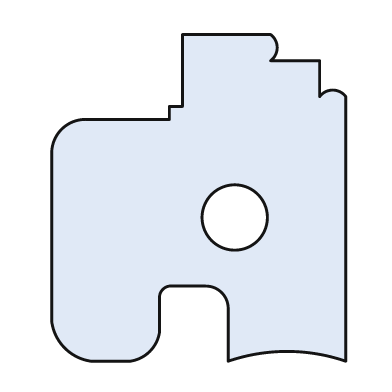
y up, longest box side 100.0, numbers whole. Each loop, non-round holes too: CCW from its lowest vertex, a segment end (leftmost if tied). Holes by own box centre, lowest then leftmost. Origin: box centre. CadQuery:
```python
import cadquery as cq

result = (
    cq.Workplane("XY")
    .moveTo(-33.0, -50.0)
    .lineTo(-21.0, -50.0)
    .threePointArc((-15.0, -47.0), (-12.0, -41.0))
    .lineTo(-12.0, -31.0)
    .threePointArc((-11.0, -28.0), (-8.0, -27.0))
    .lineTo(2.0, -27.0)
    .threePointArc((7.0, -29.0), (9.0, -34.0))
    .lineTo(9.0, -50.0)
    .threePointArc((27.0, -47.0), (45.0, -50.0))
    .lineTo(45.0, 31.0)
    .threePointArc((41.0, 33.0), (37.0, 31.0))
    .lineTo(37.0, 42.0)
    .lineTo(22.0, 42.0)
    .threePointArc((24.0, 46.0), (22.0, 50.0))
    .lineTo(-5.0, 50.0)
    .lineTo(-5.0, 28.0)
    .lineTo(-9.0, 28.0)
    .lineTo(-9.0, 24.0)
    .lineTo(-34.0, 24.0)
    .threePointArc((-42.0, 21.0), (-45.0, 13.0))
    .lineTo(-45.0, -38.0)
    .threePointArc((-41.0, -46.0), (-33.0, -50.0))
    .close()
    .moveTo(11.0, -6.0)
    .circle(10.0)
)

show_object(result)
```